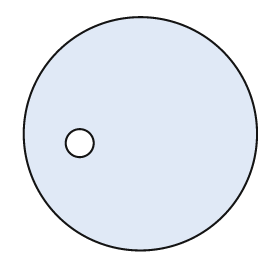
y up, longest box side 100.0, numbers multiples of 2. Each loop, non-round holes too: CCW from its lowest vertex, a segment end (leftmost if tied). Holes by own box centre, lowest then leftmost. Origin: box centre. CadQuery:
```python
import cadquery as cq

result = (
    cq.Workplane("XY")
    .moveTo(0.0, 0.0)
    .circle(50.0)
    .moveTo(-26.0, -4.0)
    .circle(6.0)
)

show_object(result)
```